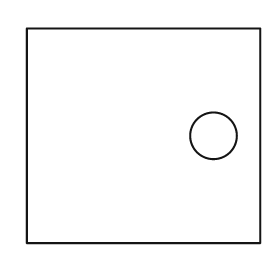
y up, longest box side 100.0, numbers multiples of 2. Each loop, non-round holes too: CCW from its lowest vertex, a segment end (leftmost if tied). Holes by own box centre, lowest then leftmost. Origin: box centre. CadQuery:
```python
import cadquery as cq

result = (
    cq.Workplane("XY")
    .moveTo(-50.0, -46.0)
    .lineTo(50.0, -46.0)
    .lineTo(50.0, 46.0)
    .lineTo(-50.0, 46.0)
    .close()
    .moveTo(30.0, 0.0)
    .circle(10.0)
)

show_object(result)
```